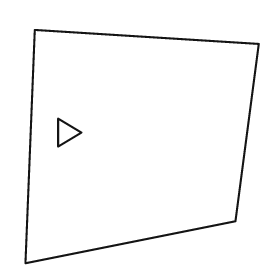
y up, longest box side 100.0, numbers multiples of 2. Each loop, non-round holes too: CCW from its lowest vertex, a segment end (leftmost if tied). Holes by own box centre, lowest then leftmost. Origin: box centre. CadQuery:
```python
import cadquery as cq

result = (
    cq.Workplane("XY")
    .moveTo(-50.0, -50.0)
    .lineTo(40.0, -32.0)
    .lineTo(50.0, 44.0)
    .lineTo(-46.0, 50.0)
    .close()
    .moveTo(-36.0, 0.0)
    .lineTo(-26.0, 6.0)
    .lineTo(-36.0, 12.0)
    .close()
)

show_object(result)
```